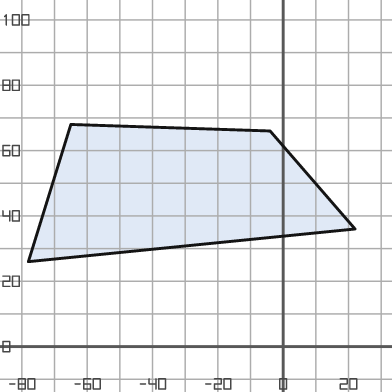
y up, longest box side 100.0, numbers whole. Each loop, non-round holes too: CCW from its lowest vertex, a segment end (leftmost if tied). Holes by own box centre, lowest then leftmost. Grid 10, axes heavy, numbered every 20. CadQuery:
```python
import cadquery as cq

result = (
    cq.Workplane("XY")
    .moveTo(-78.0, 26.0)
    .lineTo(22.0, 36.0)
    .lineTo(-4.0, 66.0)
    .lineTo(-65.0, 68.0)
    .close()
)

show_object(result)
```